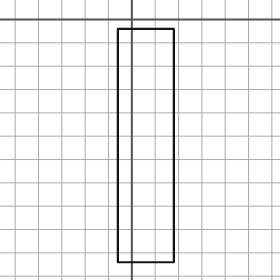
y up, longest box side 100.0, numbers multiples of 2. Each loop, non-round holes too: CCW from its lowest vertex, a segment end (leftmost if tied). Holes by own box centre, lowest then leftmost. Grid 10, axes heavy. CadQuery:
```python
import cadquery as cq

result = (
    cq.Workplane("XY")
    .moveTo(-6.0, -104.0)
    .lineTo(18.0, -104.0)
    .lineTo(18.0, -4.0)
    .lineTo(-6.0, -4.0)
    .close()
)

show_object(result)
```